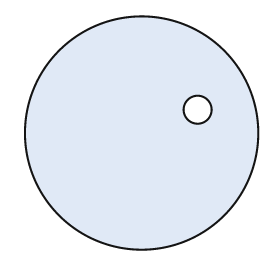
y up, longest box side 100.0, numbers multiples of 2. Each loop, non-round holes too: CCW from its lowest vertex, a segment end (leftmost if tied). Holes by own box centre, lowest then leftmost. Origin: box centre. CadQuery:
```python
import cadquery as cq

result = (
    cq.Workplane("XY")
    .moveTo(0.0, 0.0)
    .circle(50.0)
    .moveTo(24.0, 10.0)
    .circle(6.0)
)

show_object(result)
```